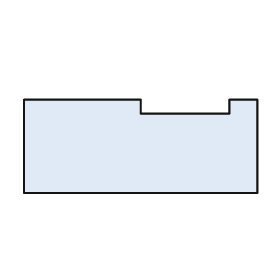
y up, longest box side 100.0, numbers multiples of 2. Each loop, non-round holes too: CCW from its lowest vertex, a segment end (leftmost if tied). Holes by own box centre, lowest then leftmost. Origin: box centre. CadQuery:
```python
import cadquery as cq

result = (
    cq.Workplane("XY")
    .moveTo(-50.0, -20.0)
    .lineTo(50.0, -20.0)
    .lineTo(50.0, 20.0)
    .lineTo(38.0, 20.0)
    .lineTo(38.0, 14.0)
    .lineTo(0.0, 14.0)
    .lineTo(0.0, 20.0)
    .lineTo(-50.0, 20.0)
    .close()
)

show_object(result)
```